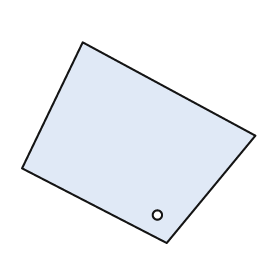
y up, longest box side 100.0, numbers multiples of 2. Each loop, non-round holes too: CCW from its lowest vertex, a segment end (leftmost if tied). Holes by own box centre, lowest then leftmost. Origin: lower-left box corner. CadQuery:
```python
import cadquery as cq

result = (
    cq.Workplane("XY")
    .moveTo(62.0, 0.0)
    .lineTo(100.0, 46.0)
    .lineTo(26.0, 86.0)
    .lineTo(0.0, 32.0)
    .close()
    .moveTo(58.0, 12.0)
    .circle(2.0)
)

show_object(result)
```